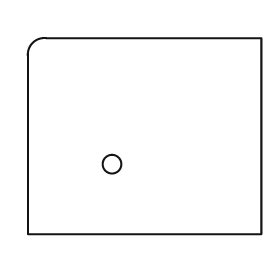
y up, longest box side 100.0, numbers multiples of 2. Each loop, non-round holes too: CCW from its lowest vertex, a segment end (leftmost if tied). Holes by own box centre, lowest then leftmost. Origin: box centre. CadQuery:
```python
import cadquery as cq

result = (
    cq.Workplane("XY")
    .moveTo(-50.0, -42.0)
    .lineTo(50.0, -42.0)
    .lineTo(50.0, 42.0)
    .lineTo(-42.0, 42.0)
    .threePointArc((-48.0, 40.0), (-50.0, 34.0))
    .close()
    .moveTo(-14.0, -12.0)
    .circle(4.0)
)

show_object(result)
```